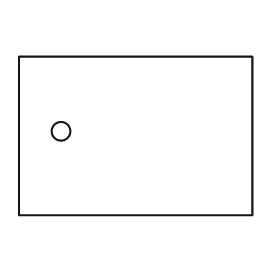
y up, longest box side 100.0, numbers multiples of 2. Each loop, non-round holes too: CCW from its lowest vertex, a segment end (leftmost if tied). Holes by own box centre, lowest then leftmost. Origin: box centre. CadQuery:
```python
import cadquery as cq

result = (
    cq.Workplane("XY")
    .moveTo(-50.0, -34.0)
    .lineTo(50.0, -34.0)
    .lineTo(50.0, 34.0)
    .lineTo(-50.0, 34.0)
    .close()
    .moveTo(-32.0, 2.0)
    .circle(4.0)
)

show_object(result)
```